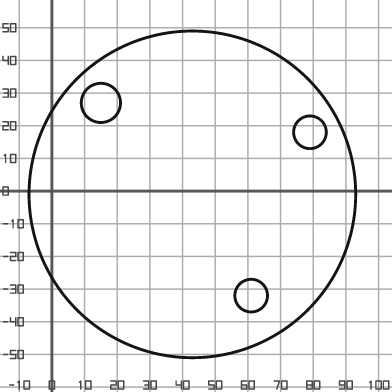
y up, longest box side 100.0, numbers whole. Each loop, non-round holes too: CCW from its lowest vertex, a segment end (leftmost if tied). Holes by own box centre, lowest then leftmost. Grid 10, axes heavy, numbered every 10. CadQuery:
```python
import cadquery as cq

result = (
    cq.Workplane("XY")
    .moveTo(43.0, -1.0)
    .circle(50.0)
    .moveTo(61.0, -32.0)
    .circle(5.0)
    .moveTo(79.0, 18.0)
    .circle(5.0)
    .moveTo(15.0, 27.0)
    .circle(6.0)
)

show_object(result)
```